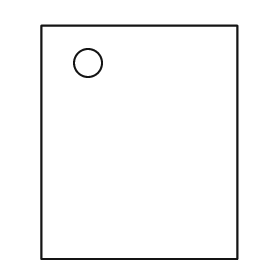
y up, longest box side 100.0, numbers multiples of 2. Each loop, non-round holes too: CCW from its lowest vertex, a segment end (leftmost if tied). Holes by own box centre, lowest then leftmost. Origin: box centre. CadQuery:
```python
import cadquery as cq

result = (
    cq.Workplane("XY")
    .moveTo(-42.0, -50.0)
    .lineTo(42.0, -50.0)
    .lineTo(42.0, 50.0)
    .lineTo(-42.0, 50.0)
    .close()
    .moveTo(-22.0, 34.0)
    .circle(6.0)
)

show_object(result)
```